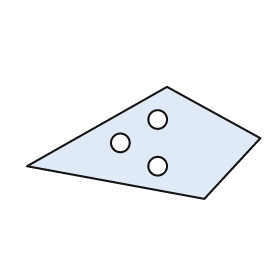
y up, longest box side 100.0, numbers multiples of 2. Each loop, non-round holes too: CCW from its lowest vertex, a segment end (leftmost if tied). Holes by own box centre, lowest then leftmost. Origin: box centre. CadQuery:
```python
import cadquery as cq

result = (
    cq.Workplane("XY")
    .moveTo(26.0, -24.0)
    .lineTo(50.0, 2.0)
    .lineTo(10.0, 24.0)
    .lineTo(-50.0, -10.0)
    .close()
    .moveTo(6.0, -10.0)
    .circle(4.0)
    .moveTo(-10.0, 0.0)
    .circle(4.0)
    .moveTo(6.0, 10.0)
    .circle(4.0)
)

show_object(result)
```